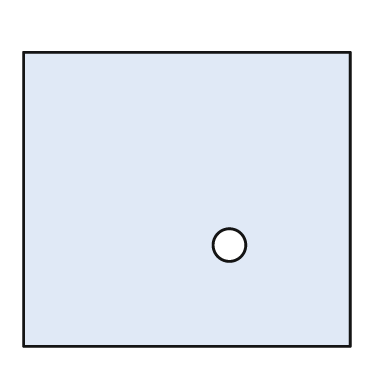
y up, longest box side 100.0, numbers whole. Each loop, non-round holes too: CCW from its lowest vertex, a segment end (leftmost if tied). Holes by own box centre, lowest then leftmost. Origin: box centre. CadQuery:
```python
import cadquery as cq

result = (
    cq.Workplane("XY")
    .moveTo(-50.0, -45.0)
    .lineTo(50.0, -45.0)
    .lineTo(50.0, 45.0)
    .lineTo(-50.0, 45.0)
    .close()
    .moveTo(13.0, -14.0)
    .circle(5.0)
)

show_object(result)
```